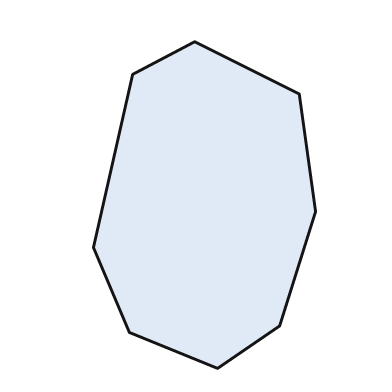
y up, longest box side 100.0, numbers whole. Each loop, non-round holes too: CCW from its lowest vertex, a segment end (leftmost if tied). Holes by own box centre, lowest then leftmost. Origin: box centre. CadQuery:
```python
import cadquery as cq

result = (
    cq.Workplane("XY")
    .moveTo(4.0, -50.0)
    .lineTo(23.0, -37.0)
    .lineTo(34.0, -2.0)
    .lineTo(29.0, 34.0)
    .lineTo(-3.0, 50.0)
    .lineTo(-22.0, 40.0)
    .lineTo(-34.0, -13.0)
    .lineTo(-23.0, -39.0)
    .close()
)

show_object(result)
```